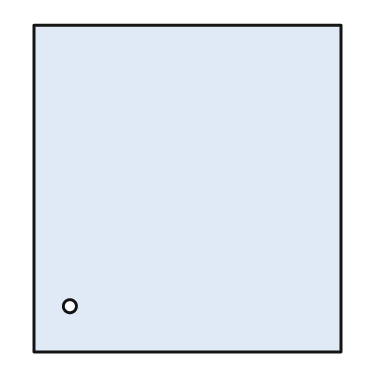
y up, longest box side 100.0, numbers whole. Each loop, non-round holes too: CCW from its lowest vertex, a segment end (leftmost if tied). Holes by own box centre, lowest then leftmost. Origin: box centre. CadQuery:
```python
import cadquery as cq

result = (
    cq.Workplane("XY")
    .moveTo(-47.0, -50.0)
    .lineTo(47.0, -50.0)
    .lineTo(47.0, 50.0)
    .lineTo(-47.0, 50.0)
    .close()
    .moveTo(-36.0, -36.0)
    .circle(2.0)
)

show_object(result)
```